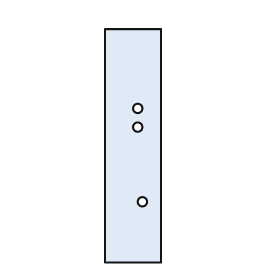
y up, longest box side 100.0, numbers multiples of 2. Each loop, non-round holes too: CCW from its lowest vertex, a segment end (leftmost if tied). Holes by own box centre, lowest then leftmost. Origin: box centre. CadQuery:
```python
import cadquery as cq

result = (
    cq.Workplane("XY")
    .moveTo(-12.0, -50.0)
    .lineTo(12.0, -50.0)
    .lineTo(12.0, 50.0)
    .lineTo(-12.0, 50.0)
    .close()
    .moveTo(4.0, -24.0)
    .circle(2.0)
    .moveTo(2.0, 8.0)
    .circle(2.0)
    .moveTo(2.0, 16.0)
    .circle(2.0)
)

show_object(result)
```